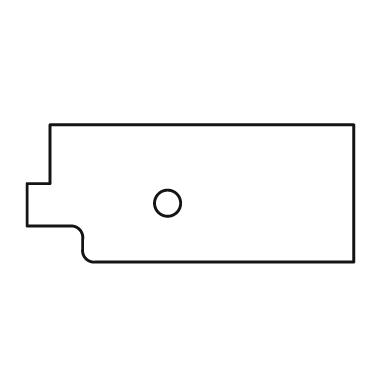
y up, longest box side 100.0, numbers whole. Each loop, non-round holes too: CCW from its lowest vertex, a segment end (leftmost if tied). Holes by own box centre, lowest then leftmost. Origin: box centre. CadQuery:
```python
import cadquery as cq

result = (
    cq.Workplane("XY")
    .moveTo(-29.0, -21.0)
    .lineTo(50.0, -21.0)
    .lineTo(50.0, 21.0)
    .lineTo(-43.0, 21.0)
    .lineTo(-43.0, 3.0)
    .lineTo(-50.0, 3.0)
    .lineTo(-50.0, -10.0)
    .lineTo(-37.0, -10.0)
    .threePointArc((-34.0, -11.0), (-33.0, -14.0))
    .lineTo(-33.0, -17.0)
    .threePointArc((-32.0, -20.0), (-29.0, -21.0))
    .close()
    .moveTo(-7.0, -3.0)
    .circle(4.0)
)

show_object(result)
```